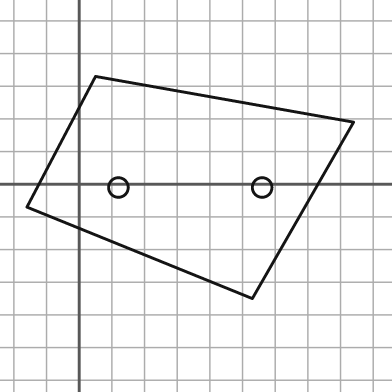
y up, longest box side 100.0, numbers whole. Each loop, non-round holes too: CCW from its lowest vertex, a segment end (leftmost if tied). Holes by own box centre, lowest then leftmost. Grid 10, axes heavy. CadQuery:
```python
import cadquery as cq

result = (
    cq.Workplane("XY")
    .moveTo(53.0, -35.0)
    .lineTo(84.0, 19.0)
    .lineTo(5.0, 33.0)
    .lineTo(-16.0, -7.0)
    .close()
    .moveTo(12.0, -1.0)
    .circle(3.0)
    .moveTo(56.0, -1.0)
    .circle(3.0)
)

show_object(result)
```